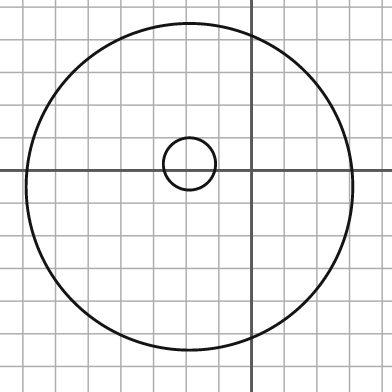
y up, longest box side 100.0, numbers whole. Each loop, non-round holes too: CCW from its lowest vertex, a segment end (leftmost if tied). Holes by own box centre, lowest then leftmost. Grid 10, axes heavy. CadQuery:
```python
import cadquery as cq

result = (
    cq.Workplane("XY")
    .moveTo(-19.0, -5.0)
    .circle(50.0)
    .moveTo(-19.0, 2.0)
    .circle(8.0)
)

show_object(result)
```